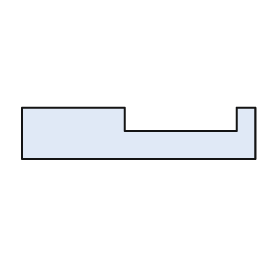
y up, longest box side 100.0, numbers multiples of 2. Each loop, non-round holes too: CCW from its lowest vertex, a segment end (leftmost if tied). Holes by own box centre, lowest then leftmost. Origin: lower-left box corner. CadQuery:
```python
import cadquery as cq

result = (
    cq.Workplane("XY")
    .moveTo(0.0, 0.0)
    .lineTo(100.0, 0.0)
    .lineTo(100.0, 22.0)
    .lineTo(92.0, 22.0)
    .lineTo(92.0, 12.0)
    .lineTo(44.0, 12.0)
    .lineTo(44.0, 22.0)
    .lineTo(0.0, 22.0)
    .close()
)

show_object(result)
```